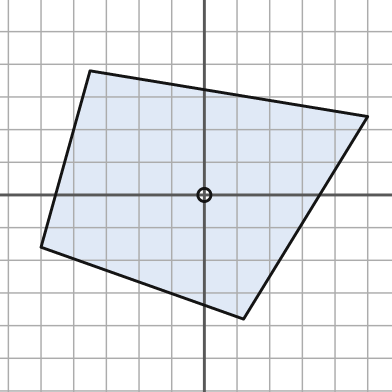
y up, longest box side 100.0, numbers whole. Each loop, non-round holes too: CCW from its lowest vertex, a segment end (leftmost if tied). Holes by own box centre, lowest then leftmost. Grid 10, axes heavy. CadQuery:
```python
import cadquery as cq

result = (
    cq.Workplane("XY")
    .moveTo(12.0, -38.0)
    .lineTo(50.0, 24.0)
    .lineTo(-35.0, 38.0)
    .lineTo(-50.0, -16.0)
    .close()
    .moveTo(0.0, 0.0)
    .circle(2.0)
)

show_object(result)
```